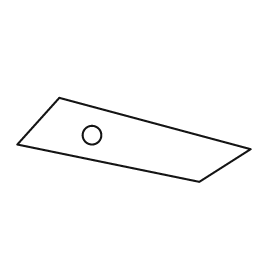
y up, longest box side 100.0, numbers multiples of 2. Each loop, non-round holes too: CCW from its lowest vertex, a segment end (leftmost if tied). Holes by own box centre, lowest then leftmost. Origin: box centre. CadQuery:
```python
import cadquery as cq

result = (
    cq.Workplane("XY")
    .moveTo(28.0, -18.0)
    .lineTo(50.0, -4.0)
    .lineTo(-32.0, 18.0)
    .lineTo(-50.0, -2.0)
    .close()
    .moveTo(-18.0, 2.0)
    .circle(4.0)
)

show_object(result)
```